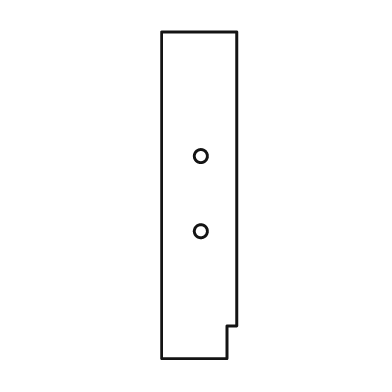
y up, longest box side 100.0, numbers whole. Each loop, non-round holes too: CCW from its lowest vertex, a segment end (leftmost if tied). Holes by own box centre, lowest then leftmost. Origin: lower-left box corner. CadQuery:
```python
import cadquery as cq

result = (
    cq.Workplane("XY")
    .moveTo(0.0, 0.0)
    .lineTo(20.0, 0.0)
    .lineTo(20.0, 10.0)
    .lineTo(23.0, 10.0)
    .lineTo(23.0, 100.0)
    .lineTo(0.0, 100.0)
    .close()
    .moveTo(12.0, 39.0)
    .circle(2.0)
    .moveTo(12.0, 62.0)
    .circle(2.0)
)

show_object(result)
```